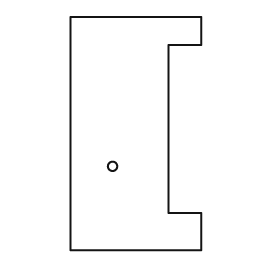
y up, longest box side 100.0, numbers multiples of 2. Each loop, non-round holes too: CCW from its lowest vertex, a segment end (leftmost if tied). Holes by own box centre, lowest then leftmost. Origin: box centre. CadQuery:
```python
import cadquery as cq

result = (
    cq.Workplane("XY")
    .moveTo(-28.0, -50.0)
    .lineTo(28.0, -50.0)
    .lineTo(28.0, -34.0)
    .lineTo(14.0, -34.0)
    .lineTo(14.0, 38.0)
    .lineTo(28.0, 38.0)
    .lineTo(28.0, 50.0)
    .lineTo(-28.0, 50.0)
    .close()
    .moveTo(-10.0, -14.0)
    .circle(2.0)
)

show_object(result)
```